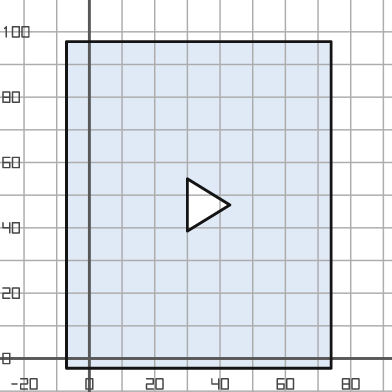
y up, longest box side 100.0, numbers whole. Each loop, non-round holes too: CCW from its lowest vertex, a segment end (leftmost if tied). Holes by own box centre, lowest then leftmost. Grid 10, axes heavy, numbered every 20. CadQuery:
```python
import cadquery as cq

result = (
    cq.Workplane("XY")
    .moveTo(-7.0, -3.0)
    .lineTo(74.0, -3.0)
    .lineTo(74.0, 97.0)
    .lineTo(-7.0, 97.0)
    .close()
    .moveTo(30.0, 39.0)
    .lineTo(43.0, 47.0)
    .lineTo(30.0, 55.0)
    .close()
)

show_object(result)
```